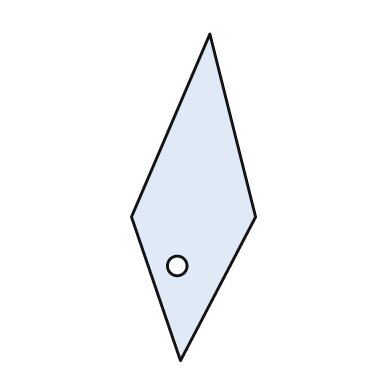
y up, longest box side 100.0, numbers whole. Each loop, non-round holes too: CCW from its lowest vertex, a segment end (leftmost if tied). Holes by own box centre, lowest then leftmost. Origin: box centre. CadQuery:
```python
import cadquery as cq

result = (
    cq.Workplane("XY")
    .moveTo(-4.0, -50.0)
    .lineTo(19.0, -6.0)
    .lineTo(5.0, 50.0)
    .lineTo(-19.0, -6.0)
    .close()
    .moveTo(-5.0, -21.0)
    .circle(3.0)
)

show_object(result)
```